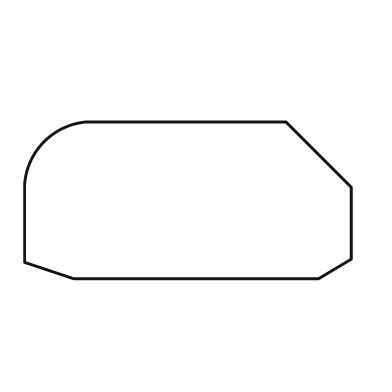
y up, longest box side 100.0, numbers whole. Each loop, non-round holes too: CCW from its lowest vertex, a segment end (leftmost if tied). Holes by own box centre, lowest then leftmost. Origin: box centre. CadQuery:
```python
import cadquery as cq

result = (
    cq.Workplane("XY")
    .moveTo(-35.0, -24.0)
    .lineTo(40.0, -24.0)
    .lineTo(50.0, -18.0)
    .lineTo(50.0, 4.0)
    .lineTo(30.0, 24.0)
    .lineTo(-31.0, 24.0)
    .threePointArc((-44.0, 18.0), (-50.0, 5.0))
    .lineTo(-50.0, -19.0)
    .close()
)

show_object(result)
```